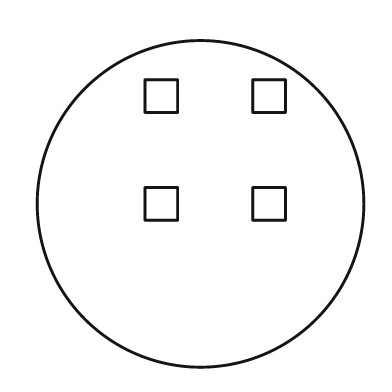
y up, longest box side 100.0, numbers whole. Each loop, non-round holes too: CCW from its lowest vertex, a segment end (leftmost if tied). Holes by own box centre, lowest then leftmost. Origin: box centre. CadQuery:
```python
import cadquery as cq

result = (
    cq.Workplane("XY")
    .moveTo(0.0, 0.0)
    .circle(50.0)
    .moveTo(-17.0, -5.0)
    .lineTo(-7.0, -5.0)
    .lineTo(-7.0, 5.0)
    .lineTo(-17.0, 5.0)
    .close()
    .moveTo(16.0, -5.0)
    .lineTo(26.0, -5.0)
    .lineTo(26.0, 5.0)
    .lineTo(16.0, 5.0)
    .close()
    .moveTo(-17.0, 28.0)
    .lineTo(-7.0, 28.0)
    .lineTo(-7.0, 38.0)
    .lineTo(-17.0, 38.0)
    .close()
    .moveTo(16.0, 28.0)
    .lineTo(26.0, 28.0)
    .lineTo(26.0, 38.0)
    .lineTo(16.0, 38.0)
    .close()
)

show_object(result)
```